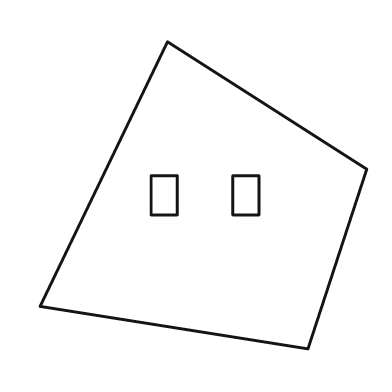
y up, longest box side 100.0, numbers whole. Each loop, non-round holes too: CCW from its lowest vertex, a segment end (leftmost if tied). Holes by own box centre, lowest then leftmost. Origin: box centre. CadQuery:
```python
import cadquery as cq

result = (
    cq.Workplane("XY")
    .moveTo(32.0, -47.0)
    .lineTo(50.0, 8.0)
    .lineTo(-11.0, 47.0)
    .lineTo(-50.0, -34.0)
    .close()
    .moveTo(-16.0, -6.0)
    .lineTo(-8.0, -6.0)
    .lineTo(-8.0, 6.0)
    .lineTo(-16.0, 6.0)
    .close()
    .moveTo(9.0, -6.0)
    .lineTo(17.0, -6.0)
    .lineTo(17.0, 6.0)
    .lineTo(9.0, 6.0)
    .close()
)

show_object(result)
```